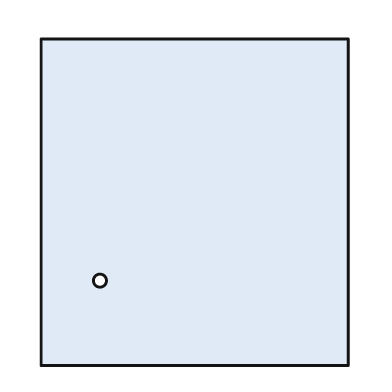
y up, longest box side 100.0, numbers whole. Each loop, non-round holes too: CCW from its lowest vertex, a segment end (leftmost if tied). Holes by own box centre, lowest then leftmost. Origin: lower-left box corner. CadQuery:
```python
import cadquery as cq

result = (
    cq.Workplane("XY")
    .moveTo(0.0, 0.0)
    .lineTo(94.0, 0.0)
    .lineTo(94.0, 100.0)
    .lineTo(0.0, 100.0)
    .close()
    .moveTo(18.0, 26.0)
    .circle(2.0)
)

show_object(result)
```